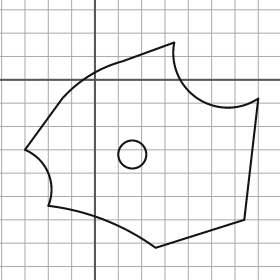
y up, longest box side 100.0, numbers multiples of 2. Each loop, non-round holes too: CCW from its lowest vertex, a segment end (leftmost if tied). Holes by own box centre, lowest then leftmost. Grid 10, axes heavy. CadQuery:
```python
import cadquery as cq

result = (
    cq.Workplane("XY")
    .moveTo(26.0, -72.0)
    .lineTo(64.0, -60.0)
    .lineTo(70.0, -8.0)
    .threePointArc((44.0, -8.0), (34.0, 16.0))
    .lineTo(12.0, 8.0)
    .threePointArc((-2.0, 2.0), (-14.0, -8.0))
    .lineTo(-30.0, -30.0)
    .threePointArc((-20.0, -40.0), (-20.0, -54.0))
    .threePointArc((4.0, -60.0), (26.0, -72.0))
    .close()
    .moveTo(16.0, -32.0)
    .circle(6.0)
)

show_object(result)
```